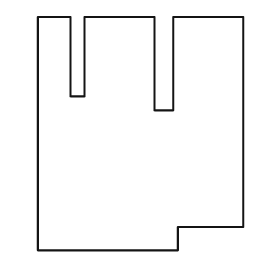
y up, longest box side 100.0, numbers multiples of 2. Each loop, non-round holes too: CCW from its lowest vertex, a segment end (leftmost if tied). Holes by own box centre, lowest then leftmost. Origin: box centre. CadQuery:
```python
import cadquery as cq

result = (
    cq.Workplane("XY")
    .moveTo(-44.0, -50.0)
    .lineTo(16.0, -50.0)
    .lineTo(16.0, -40.0)
    .lineTo(44.0, -40.0)
    .lineTo(44.0, 50.0)
    .lineTo(14.0, 50.0)
    .lineTo(14.0, 10.0)
    .lineTo(6.0, 10.0)
    .lineTo(6.0, 50.0)
    .lineTo(-24.0, 50.0)
    .lineTo(-24.0, 16.0)
    .lineTo(-30.0, 16.0)
    .lineTo(-30.0, 50.0)
    .lineTo(-44.0, 50.0)
    .close()
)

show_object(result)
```